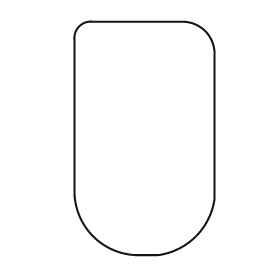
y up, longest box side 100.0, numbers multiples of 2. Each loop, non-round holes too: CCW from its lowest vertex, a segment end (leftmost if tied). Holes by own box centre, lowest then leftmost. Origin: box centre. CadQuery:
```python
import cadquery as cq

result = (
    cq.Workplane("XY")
    .moveTo(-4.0, -50.0)
    .lineTo(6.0, -50.0)
    .threePointArc((22.0, -42.0), (30.0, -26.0))
    .lineTo(30.0, 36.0)
    .threePointArc((26.0, 46.0), (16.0, 50.0))
    .lineTo(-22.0, 50.0)
    .threePointArc((-28.0, 48.0), (-30.0, 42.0))
    .lineTo(-30.0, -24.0)
    .threePointArc((-22.0, -42.0), (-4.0, -50.0))
    .close()
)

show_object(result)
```